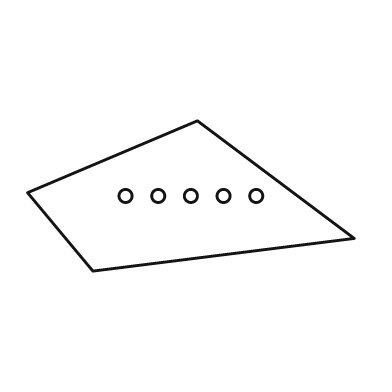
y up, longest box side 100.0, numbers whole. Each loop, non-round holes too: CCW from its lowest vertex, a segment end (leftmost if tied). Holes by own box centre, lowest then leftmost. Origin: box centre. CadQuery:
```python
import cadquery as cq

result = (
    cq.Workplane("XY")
    .moveTo(-30.0, -23.0)
    .lineTo(50.0, -13.0)
    .lineTo(2.0, 23.0)
    .lineTo(-50.0, 1.0)
    .close()
    .moveTo(-20.0, 0.0)
    .circle(2.0)
    .moveTo(-10.0, 0.0)
    .circle(2.0)
    .moveTo(0.0, 0.0)
    .circle(2.0)
    .moveTo(10.0, 0.0)
    .circle(2.0)
    .moveTo(20.0, 0.0)
    .circle(2.0)
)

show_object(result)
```